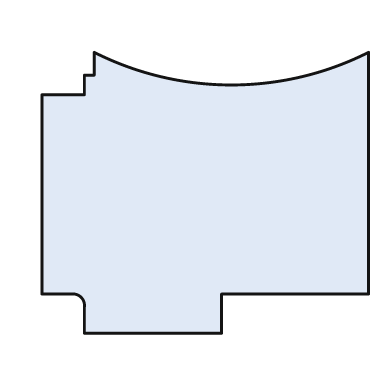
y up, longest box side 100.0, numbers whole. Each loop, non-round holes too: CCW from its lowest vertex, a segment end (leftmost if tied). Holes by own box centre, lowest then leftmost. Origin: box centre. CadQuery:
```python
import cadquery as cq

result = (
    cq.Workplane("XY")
    .moveTo(-37.0, -43.0)
    .lineTo(5.0, -43.0)
    .lineTo(5.0, -31.0)
    .lineTo(50.0, -31.0)
    .lineTo(50.0, 43.0)
    .threePointArc((8.0, 33.0), (-34.0, 43.0))
    .lineTo(-34.0, 36.0)
    .lineTo(-37.0, 36.0)
    .lineTo(-37.0, 30.0)
    .lineTo(-50.0, 30.0)
    .lineTo(-50.0, -31.0)
    .lineTo(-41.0, -31.0)
    .threePointArc((-38.0, -32.0), (-37.0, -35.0))
    .close()
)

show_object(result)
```